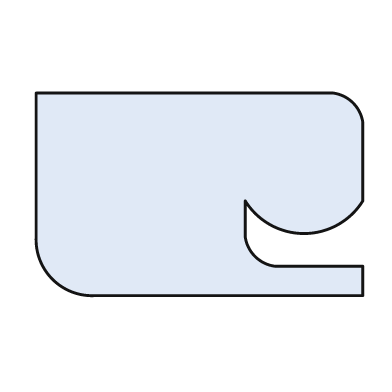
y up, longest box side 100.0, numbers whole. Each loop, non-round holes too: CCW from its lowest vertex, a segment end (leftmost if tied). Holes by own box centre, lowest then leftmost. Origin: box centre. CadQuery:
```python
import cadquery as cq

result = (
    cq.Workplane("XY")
    .moveTo(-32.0, -31.0)
    .lineTo(50.0, -31.0)
    .lineTo(50.0, -22.0)
    .lineTo(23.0, -22.0)
    .threePointArc((17.0, -19.0), (14.0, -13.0))
    .lineTo(14.0, -2.0)
    .threePointArc((32.0, -12.0), (50.0, -2.0))
    .lineTo(50.0, 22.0)
    .threePointArc((47.0, 28.0), (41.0, 31.0))
    .lineTo(-50.0, 31.0)
    .lineTo(-50.0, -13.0)
    .threePointArc((-45.0, -26.0), (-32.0, -31.0))
    .close()
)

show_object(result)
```